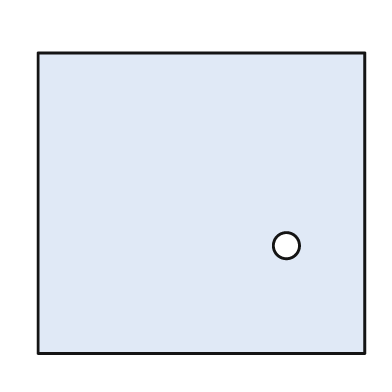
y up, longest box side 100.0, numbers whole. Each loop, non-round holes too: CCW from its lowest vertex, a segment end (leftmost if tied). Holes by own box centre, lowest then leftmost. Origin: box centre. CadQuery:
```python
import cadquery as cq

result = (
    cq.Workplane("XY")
    .moveTo(-50.0, -46.0)
    .lineTo(50.0, -46.0)
    .lineTo(50.0, 46.0)
    .lineTo(-50.0, 46.0)
    .close()
    .moveTo(26.0, -13.0)
    .circle(4.0)
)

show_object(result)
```